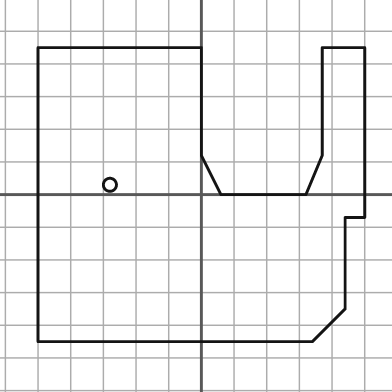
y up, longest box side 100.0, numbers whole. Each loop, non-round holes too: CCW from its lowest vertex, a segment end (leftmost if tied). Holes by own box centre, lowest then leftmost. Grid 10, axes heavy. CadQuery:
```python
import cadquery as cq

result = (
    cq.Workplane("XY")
    .moveTo(-50.0, -45.0)
    .lineTo(34.0, -45.0)
    .lineTo(44.0, -35.0)
    .lineTo(44.0, -7.0)
    .lineTo(50.0, -7.0)
    .lineTo(50.0, 45.0)
    .lineTo(37.0, 45.0)
    .lineTo(37.0, 12.0)
    .lineTo(32.0, 0.0)
    .lineTo(6.0, 0.0)
    .lineTo(0.0, 12.0)
    .lineTo(0.0, 45.0)
    .lineTo(-50.0, 45.0)
    .close()
    .moveTo(-28.0, 3.0)
    .circle(2.0)
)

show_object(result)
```